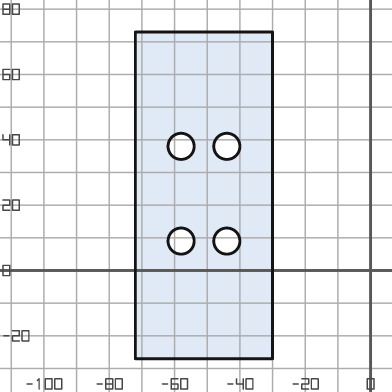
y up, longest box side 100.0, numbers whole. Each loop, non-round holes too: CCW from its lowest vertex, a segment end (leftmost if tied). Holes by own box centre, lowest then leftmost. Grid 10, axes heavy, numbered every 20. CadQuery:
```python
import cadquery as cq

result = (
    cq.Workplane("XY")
    .moveTo(-72.0, -27.0)
    .lineTo(-30.0, -27.0)
    .lineTo(-30.0, 73.0)
    .lineTo(-72.0, 73.0)
    .close()
    .moveTo(-58.0, 9.0)
    .circle(4.0)
    .moveTo(-44.0, 9.0)
    .circle(4.0)
    .moveTo(-58.0, 38.0)
    .circle(4.0)
    .moveTo(-44.0, 38.0)
    .circle(4.0)
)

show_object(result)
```